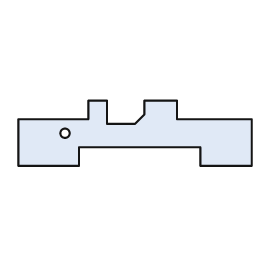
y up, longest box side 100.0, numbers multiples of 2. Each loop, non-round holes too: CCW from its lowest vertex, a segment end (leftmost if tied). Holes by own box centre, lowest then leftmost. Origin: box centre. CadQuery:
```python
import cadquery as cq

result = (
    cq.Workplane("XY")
    .moveTo(-50.0, -14.0)
    .lineTo(-24.0, -14.0)
    .lineTo(-24.0, -6.0)
    .lineTo(28.0, -6.0)
    .lineTo(28.0, -14.0)
    .lineTo(50.0, -14.0)
    .lineTo(50.0, 6.0)
    .lineTo(18.0, 6.0)
    .lineTo(18.0, 14.0)
    .lineTo(4.0, 14.0)
    .lineTo(4.0, 8.0)
    .lineTo(0.0, 4.0)
    .lineTo(-12.0, 4.0)
    .lineTo(-12.0, 14.0)
    .lineTo(-20.0, 14.0)
    .lineTo(-20.0, 6.0)
    .lineTo(-50.0, 6.0)
    .close()
    .moveTo(-30.0, 0.0)
    .circle(2.0)
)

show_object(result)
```